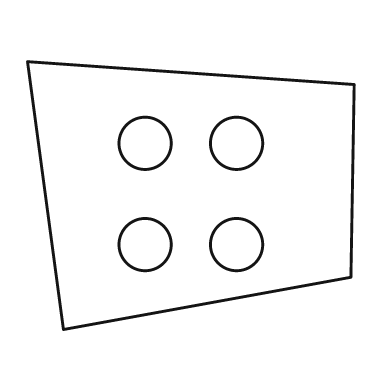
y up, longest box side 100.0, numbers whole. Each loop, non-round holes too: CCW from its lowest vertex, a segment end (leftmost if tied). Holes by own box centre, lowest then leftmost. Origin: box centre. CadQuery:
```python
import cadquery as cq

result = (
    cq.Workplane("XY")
    .moveTo(-39.0, -41.0)
    .lineTo(49.0, -25.0)
    .lineTo(50.0, 34.0)
    .lineTo(-50.0, 41.0)
    .close()
    .moveTo(-14.0, -15.0)
    .circle(8.0)
    .moveTo(14.0, -15.0)
    .circle(8.0)
    .moveTo(-14.0, 16.0)
    .circle(8.0)
    .moveTo(14.0, 16.0)
    .circle(8.0)
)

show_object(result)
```